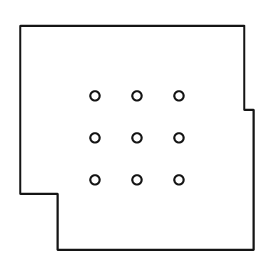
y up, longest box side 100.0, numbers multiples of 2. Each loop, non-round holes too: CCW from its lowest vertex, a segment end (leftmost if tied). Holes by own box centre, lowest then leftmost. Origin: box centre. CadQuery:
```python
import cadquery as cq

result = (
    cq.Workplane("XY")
    .moveTo(-34.0, -48.0)
    .lineTo(50.0, -48.0)
    .lineTo(50.0, 12.0)
    .lineTo(46.0, 12.0)
    .lineTo(46.0, 48.0)
    .lineTo(-50.0, 48.0)
    .lineTo(-50.0, -24.0)
    .lineTo(-34.0, -24.0)
    .close()
    .moveTo(-18.0, -18.0)
    .circle(2.0)
    .moveTo(0.0, -18.0)
    .circle(2.0)
    .moveTo(18.0, -18.0)
    .circle(2.0)
    .moveTo(-18.0, 0.0)
    .circle(2.0)
    .moveTo(0.0, 0.0)
    .circle(2.0)
    .moveTo(18.0, 0.0)
    .circle(2.0)
    .moveTo(-18.0, 18.0)
    .circle(2.0)
    .moveTo(0.0, 18.0)
    .circle(2.0)
    .moveTo(18.0, 18.0)
    .circle(2.0)
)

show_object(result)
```